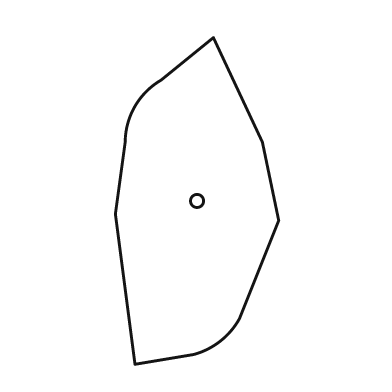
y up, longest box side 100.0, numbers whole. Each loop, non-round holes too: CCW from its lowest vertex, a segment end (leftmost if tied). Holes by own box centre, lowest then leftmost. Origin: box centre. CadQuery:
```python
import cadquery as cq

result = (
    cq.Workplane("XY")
    .moveTo(-19.0, -50.0)
    .lineTo(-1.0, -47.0)
    .threePointArc((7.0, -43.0), (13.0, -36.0))
    .lineTo(25.0, -6.0)
    .lineTo(20.0, 18.0)
    .lineTo(5.0, 50.0)
    .lineTo(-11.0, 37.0)
    .threePointArc((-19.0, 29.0), (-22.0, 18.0))
    .lineTo(-25.0, -4.0)
    .close()
    .moveTo(0.0, 0.0)
    .circle(2.0)
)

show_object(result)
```